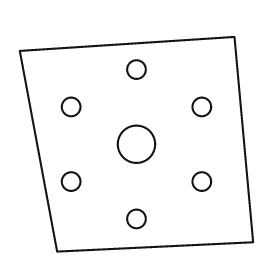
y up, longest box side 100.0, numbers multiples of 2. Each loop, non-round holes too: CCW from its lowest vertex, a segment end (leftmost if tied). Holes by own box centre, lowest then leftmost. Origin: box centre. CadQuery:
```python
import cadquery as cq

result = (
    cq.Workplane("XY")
    .moveTo(-34.0, -46.0)
    .lineTo(50.0, -42.0)
    .lineTo(42.0, 46.0)
    .lineTo(-50.0, 40.0)
    .close()
    .moveTo(0.0, -32.0)
    .circle(4.0)
    .moveTo(-28.0, -16.0)
    .circle(4.0)
    .moveTo(28.0, -16.0)
    .circle(4.0)
    .moveTo(0.0, 0.0)
    .circle(8.0)
    .moveTo(-28.0, 16.0)
    .circle(4.0)
    .moveTo(28.0, 16.0)
    .circle(4.0)
    .moveTo(0.0, 32.0)
    .circle(4.0)
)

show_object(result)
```